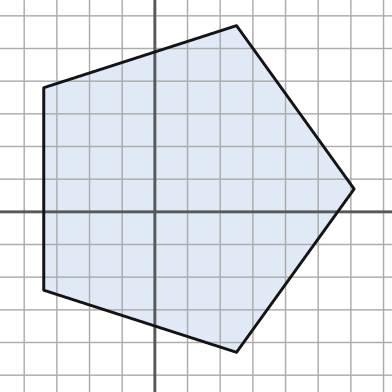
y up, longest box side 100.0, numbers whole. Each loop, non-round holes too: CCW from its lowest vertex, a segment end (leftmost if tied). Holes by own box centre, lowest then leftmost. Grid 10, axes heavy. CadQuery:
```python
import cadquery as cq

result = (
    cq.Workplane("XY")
    .moveTo(25.0, -43.0)
    .lineTo(61.0, 7.0)
    .lineTo(25.0, 57.0)
    .lineTo(-34.0, 38.0)
    .lineTo(-34.0, -24.0)
    .close()
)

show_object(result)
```